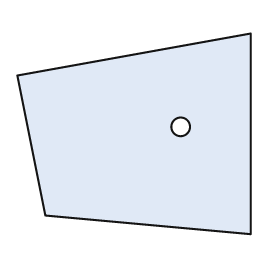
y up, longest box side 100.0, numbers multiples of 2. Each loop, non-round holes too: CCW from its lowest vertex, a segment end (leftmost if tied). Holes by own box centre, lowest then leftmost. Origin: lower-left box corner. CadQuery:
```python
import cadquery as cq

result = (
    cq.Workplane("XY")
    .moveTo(100.0, 0.0)
    .lineTo(100.0, 86.0)
    .lineTo(0.0, 68.0)
    .lineTo(12.0, 8.0)
    .close()
    .moveTo(70.0, 46.0)
    .circle(4.0)
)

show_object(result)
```